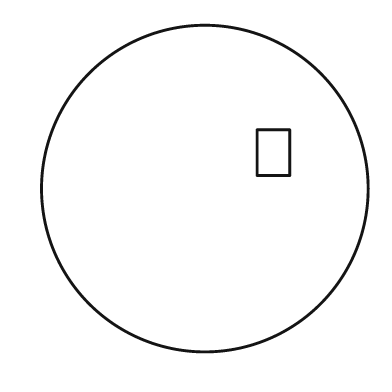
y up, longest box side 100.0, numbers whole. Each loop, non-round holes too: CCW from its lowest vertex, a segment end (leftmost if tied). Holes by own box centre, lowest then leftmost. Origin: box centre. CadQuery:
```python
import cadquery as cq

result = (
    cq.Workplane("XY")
    .moveTo(0.0, 0.0)
    .circle(50.0)
    .moveTo(16.0, 4.0)
    .lineTo(26.0, 4.0)
    .lineTo(26.0, 18.0)
    .lineTo(16.0, 18.0)
    .close()
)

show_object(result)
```